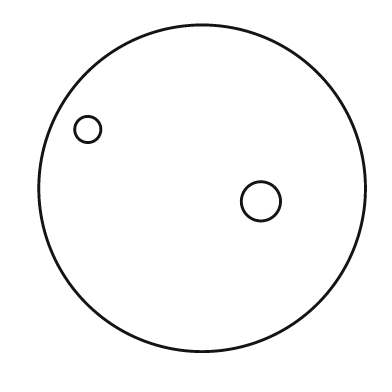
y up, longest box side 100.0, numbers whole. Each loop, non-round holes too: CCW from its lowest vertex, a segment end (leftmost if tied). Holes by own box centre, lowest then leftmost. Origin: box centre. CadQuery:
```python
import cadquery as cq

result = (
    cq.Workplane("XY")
    .moveTo(0.0, 0.0)
    .circle(50.0)
    .moveTo(18.0, -4.0)
    .circle(6.0)
    .moveTo(-35.0, 18.0)
    .circle(4.0)
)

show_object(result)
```